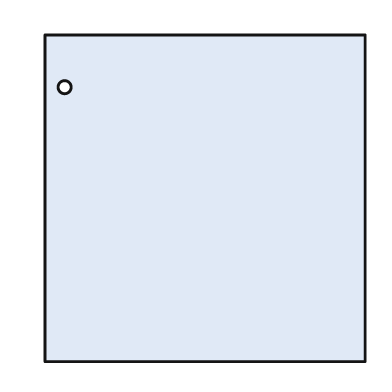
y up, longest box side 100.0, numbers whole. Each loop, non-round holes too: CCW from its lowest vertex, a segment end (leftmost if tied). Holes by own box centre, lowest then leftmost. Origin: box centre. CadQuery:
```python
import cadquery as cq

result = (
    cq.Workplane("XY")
    .moveTo(-49.0, -50.0)
    .lineTo(49.0, -50.0)
    .lineTo(49.0, 50.0)
    .lineTo(-49.0, 50.0)
    .close()
    .moveTo(-43.0, 34.0)
    .circle(2.0)
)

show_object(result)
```